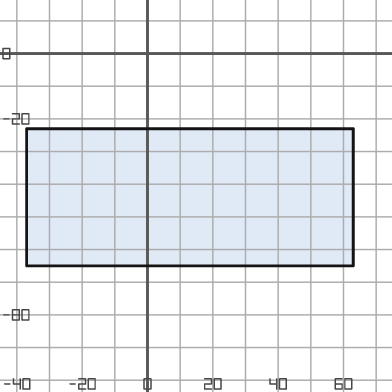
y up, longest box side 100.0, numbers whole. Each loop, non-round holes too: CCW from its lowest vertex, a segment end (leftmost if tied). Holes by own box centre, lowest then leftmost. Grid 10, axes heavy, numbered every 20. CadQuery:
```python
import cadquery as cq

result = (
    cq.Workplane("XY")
    .moveTo(-37.0, -65.0)
    .lineTo(63.0, -65.0)
    .lineTo(63.0, -23.0)
    .lineTo(-37.0, -23.0)
    .close()
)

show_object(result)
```